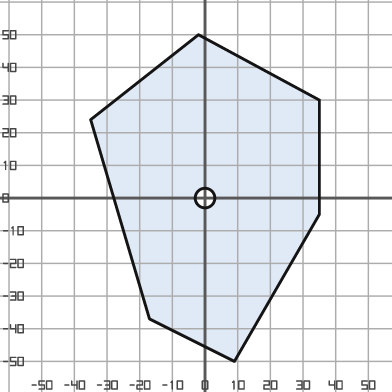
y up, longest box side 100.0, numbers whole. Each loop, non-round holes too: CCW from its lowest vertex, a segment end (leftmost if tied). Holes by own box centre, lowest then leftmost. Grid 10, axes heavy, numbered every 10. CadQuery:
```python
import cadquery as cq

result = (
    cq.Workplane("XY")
    .moveTo(9.0, -50.0)
    .lineTo(35.0, -5.0)
    .lineTo(35.0, 30.0)
    .lineTo(-2.0, 50.0)
    .lineTo(-35.0, 24.0)
    .lineTo(-17.0, -37.0)
    .close()
    .moveTo(0.0, 0.0)
    .circle(3.0)
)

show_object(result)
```